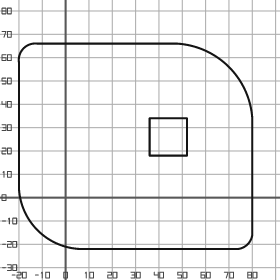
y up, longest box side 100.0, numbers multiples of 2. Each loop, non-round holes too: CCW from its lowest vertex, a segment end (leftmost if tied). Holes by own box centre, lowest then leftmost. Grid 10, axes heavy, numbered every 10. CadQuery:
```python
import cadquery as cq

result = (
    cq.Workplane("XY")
    .moveTo(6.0, -22.0)
    .lineTo(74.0, -22.0)
    .threePointArc((78.0, -20.0), (80.0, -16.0))
    .lineTo(80.0, 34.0)
    .threePointArc((70.0, 56.0), (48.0, 66.0))
    .lineTo(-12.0, 66.0)
    .threePointArc((-18.0, 64.0), (-20.0, 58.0))
    .lineTo(-20.0, 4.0)
    .threePointArc((-12.0, -14.0), (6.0, -22.0))
    .close()
    .moveTo(36.0, 18.0)
    .lineTo(52.0, 18.0)
    .lineTo(52.0, 34.0)
    .lineTo(36.0, 34.0)
    .close()
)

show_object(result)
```